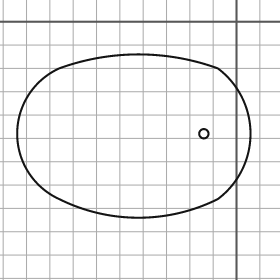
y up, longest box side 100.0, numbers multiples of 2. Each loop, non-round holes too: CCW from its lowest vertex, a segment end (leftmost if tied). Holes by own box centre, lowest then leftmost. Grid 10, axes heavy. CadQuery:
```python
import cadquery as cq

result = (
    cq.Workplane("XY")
    .moveTo(-76.0, -76.0)
    .threePointArc((-42.0, -84.0), (-8.0, -76.0))
    .threePointArc((6.0, -48.0), (-8.0, -20.0))
    .threePointArc((-42.0, -14.0), (-76.0, -20.0))
    .threePointArc((-94.0, -48.0), (-76.0, -76.0))
    .close()
    .moveTo(-14.0, -48.0)
    .circle(2.0)
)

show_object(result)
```